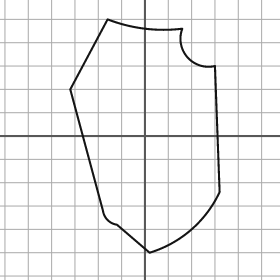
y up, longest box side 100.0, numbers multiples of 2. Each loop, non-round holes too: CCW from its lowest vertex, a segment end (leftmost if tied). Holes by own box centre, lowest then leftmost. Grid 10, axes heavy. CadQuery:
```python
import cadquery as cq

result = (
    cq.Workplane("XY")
    .moveTo(2.0, -50.0)
    .threePointArc((20.0, -40.0), (32.0, -24.0))
    .lineTo(30.0, 30.0)
    .threePointArc((18.0, 34.0), (16.0, 46.0))
    .threePointArc((0.0, 46.0), (-16.0, 50.0))
    .lineTo(-32.0, 20.0)
    .lineTo(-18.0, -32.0)
    .threePointArc((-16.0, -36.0), (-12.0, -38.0))
    .close()
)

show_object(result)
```